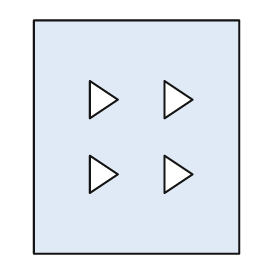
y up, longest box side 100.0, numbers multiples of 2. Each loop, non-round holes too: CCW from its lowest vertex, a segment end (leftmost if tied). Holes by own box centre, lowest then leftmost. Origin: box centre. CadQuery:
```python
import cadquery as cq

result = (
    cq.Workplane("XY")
    .moveTo(-44.0, -50.0)
    .lineTo(44.0, -50.0)
    .lineTo(44.0, 50.0)
    .lineTo(-44.0, 50.0)
    .close()
    .moveTo(-20.0, -24.0)
    .lineTo(-8.0, -16.0)
    .lineTo(-20.0, -8.0)
    .close()
    .moveTo(12.0, -24.0)
    .lineTo(24.0, -16.0)
    .lineTo(12.0, -8.0)
    .close()
    .moveTo(-20.0, 8.0)
    .lineTo(-8.0, 16.0)
    .lineTo(-20.0, 24.0)
    .close()
    .moveTo(12.0, 8.0)
    .lineTo(24.0, 16.0)
    .lineTo(12.0, 24.0)
    .close()
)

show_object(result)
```